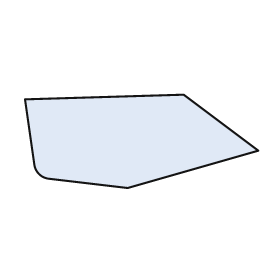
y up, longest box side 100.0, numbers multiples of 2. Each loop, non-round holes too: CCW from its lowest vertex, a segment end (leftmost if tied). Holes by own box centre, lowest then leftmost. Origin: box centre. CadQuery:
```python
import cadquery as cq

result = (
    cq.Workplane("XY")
    .moveTo(-6.0, -20.0)
    .lineTo(50.0, -4.0)
    .lineTo(18.0, 20.0)
    .lineTo(-50.0, 18.0)
    .lineTo(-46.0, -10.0)
    .threePointArc((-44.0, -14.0), (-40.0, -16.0))
    .close()
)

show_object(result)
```